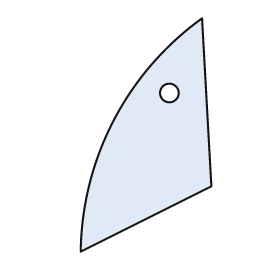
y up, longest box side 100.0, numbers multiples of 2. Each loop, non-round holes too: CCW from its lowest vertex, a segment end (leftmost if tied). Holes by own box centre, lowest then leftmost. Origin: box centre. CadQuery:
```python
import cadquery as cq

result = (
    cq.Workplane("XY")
    .moveTo(-28.0, -50.0)
    .lineTo(28.0, -22.0)
    .lineTo(24.0, 50.0)
    .threePointArc((-14.0, 6.0), (-28.0, -50.0))
    .close()
    .moveTo(10.0, 18.0)
    .circle(4.0)
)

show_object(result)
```